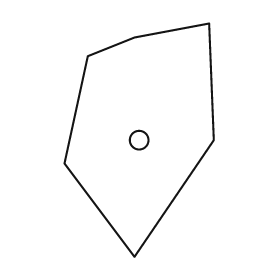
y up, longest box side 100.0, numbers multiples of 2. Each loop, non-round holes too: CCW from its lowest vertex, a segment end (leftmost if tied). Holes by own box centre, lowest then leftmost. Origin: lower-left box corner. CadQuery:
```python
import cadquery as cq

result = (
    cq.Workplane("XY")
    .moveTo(30.0, 0.0)
    .lineTo(64.0, 50.0)
    .lineTo(62.0, 100.0)
    .lineTo(30.0, 94.0)
    .lineTo(10.0, 86.0)
    .lineTo(0.0, 40.0)
    .close()
    .moveTo(32.0, 50.0)
    .circle(4.0)
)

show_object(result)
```